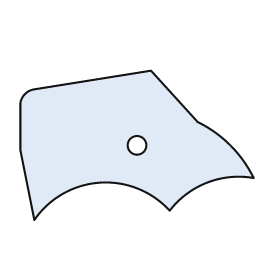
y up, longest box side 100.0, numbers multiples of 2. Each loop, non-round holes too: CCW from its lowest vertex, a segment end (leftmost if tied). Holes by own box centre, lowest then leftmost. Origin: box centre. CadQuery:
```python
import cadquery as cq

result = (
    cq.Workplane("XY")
    .moveTo(-44.0, -32.0)
    .threePointArc((-16.0, -16.0), (14.0, -28.0))
    .threePointArc((30.0, -16.0), (50.0, -14.0))
    .threePointArc((40.0, 0.0), (26.0, 10.0))
    .lineTo(6.0, 32.0)
    .lineTo(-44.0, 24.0)
    .threePointArc((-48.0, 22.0), (-50.0, 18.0))
    .lineTo(-50.0, -2.0)
    .close()
    .moveTo(0.0, 0.0)
    .circle(4.0)
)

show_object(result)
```